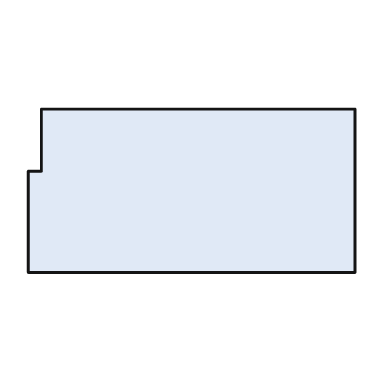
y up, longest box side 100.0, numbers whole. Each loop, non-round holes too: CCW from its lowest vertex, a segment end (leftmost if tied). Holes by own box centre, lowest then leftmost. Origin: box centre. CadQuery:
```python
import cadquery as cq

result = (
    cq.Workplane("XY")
    .moveTo(-50.0, -25.0)
    .lineTo(50.0, -25.0)
    .lineTo(50.0, 25.0)
    .lineTo(-46.0, 25.0)
    .lineTo(-46.0, 6.0)
    .lineTo(-50.0, 6.0)
    .close()
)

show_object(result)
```